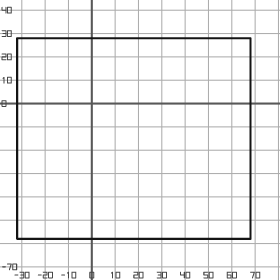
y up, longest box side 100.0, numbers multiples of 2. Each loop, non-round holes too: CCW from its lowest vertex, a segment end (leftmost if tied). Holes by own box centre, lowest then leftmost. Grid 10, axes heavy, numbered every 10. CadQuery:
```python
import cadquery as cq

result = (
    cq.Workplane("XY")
    .moveTo(-32.0, -58.0)
    .lineTo(68.0, -58.0)
    .lineTo(68.0, 28.0)
    .lineTo(-32.0, 28.0)
    .close()
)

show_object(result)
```